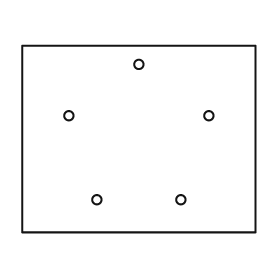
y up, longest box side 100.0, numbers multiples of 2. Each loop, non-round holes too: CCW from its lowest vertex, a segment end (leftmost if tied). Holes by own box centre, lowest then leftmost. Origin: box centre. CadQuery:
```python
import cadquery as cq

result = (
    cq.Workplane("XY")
    .moveTo(-50.0, -40.0)
    .lineTo(50.0, -40.0)
    .lineTo(50.0, 40.0)
    .lineTo(-50.0, 40.0)
    .close()
    .moveTo(-18.0, -26.0)
    .circle(2.0)
    .moveTo(18.0, -26.0)
    .circle(2.0)
    .moveTo(-30.0, 10.0)
    .circle(2.0)
    .moveTo(30.0, 10.0)
    .circle(2.0)
    .moveTo(0.0, 32.0)
    .circle(2.0)
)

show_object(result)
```